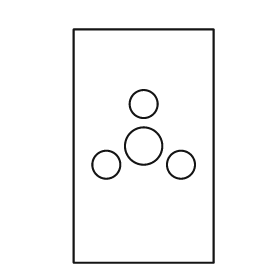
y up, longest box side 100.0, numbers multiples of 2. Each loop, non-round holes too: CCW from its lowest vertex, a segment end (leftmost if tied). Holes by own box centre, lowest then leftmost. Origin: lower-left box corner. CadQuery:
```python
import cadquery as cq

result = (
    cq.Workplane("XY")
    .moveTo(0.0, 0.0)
    .lineTo(60.0, 0.0)
    .lineTo(60.0, 100.0)
    .lineTo(0.0, 100.0)
    .close()
    .moveTo(14.0, 42.0)
    .circle(6.0)
    .moveTo(46.0, 42.0)
    .circle(6.0)
    .moveTo(30.0, 50.0)
    .circle(8.0)
    .moveTo(30.0, 68.0)
    .circle(6.0)
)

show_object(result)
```